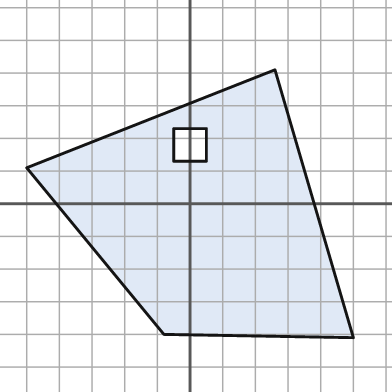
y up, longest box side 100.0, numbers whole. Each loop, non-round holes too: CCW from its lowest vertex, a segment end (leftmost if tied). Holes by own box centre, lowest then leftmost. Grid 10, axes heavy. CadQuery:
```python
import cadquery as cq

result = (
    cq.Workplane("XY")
    .moveTo(50.0, -41.0)
    .lineTo(26.0, 41.0)
    .lineTo(-50.0, 11.0)
    .lineTo(-8.0, -40.0)
    .close()
    .moveTo(-5.0, 13.0)
    .lineTo(5.0, 13.0)
    .lineTo(5.0, 23.0)
    .lineTo(-5.0, 23.0)
    .close()
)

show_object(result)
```